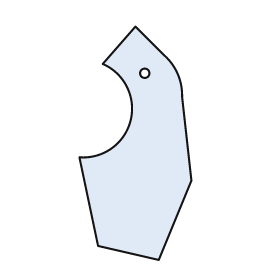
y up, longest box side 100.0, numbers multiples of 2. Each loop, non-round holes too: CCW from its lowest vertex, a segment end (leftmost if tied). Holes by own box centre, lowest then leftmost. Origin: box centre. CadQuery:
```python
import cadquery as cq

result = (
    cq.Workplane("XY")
    .moveTo(10.0, -50.0)
    .lineTo(24.0, -16.0)
    .lineTo(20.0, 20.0)
    .threePointArc((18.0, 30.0), (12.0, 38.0))
    .lineTo(0.0, 50.0)
    .lineTo(-14.0, 34.0)
    .threePointArc((-2.0, 10.0), (-24.0, -6.0))
    .lineTo(-16.0, -44.0)
    .close()
    .moveTo(4.0, 30.0)
    .circle(2.0)
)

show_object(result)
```